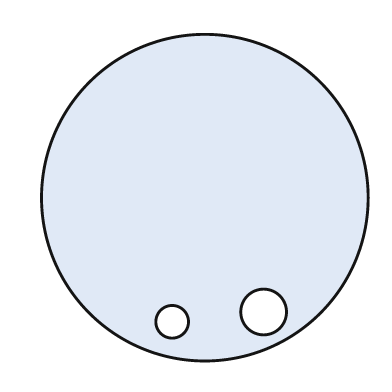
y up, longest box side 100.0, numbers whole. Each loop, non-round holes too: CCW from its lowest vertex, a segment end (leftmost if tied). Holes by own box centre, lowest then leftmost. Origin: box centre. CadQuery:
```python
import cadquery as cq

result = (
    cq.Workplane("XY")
    .moveTo(0.0, 0.0)
    .circle(50.0)
    .moveTo(-10.0, -38.0)
    .circle(5.0)
    .moveTo(18.0, -35.0)
    .circle(7.0)
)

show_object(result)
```